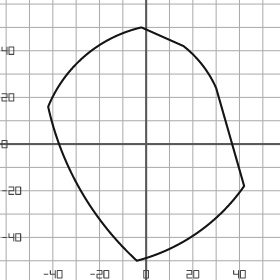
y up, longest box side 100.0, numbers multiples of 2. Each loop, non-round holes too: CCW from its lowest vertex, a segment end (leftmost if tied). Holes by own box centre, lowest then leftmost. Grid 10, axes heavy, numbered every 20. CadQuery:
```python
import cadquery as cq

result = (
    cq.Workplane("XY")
    .moveTo(-4.0, -50.0)
    .threePointArc((22.0, -38.0), (42.0, -18.0))
    .lineTo(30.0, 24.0)
    .threePointArc((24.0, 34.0), (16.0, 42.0))
    .lineTo(-2.0, 50.0)
    .threePointArc((-26.0, 38.0), (-42.0, 16.0))
    .threePointArc((-28.0, -20.0), (-4.0, -50.0))
    .close()
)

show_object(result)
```